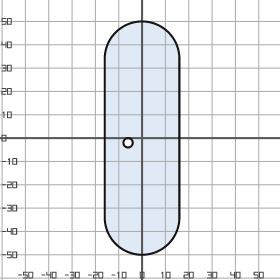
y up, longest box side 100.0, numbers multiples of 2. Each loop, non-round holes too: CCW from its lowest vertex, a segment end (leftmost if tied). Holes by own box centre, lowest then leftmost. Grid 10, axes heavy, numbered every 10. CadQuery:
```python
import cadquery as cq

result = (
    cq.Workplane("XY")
    .moveTo(-16.0, -34.0)
    .threePointArc((0.0, -50.0), (16.0, -34.0))
    .lineTo(16.0, 34.0)
    .threePointArc((0.0, 50.0), (-16.0, 34.0))
    .close()
    .moveTo(-6.0, -2.0)
    .circle(2.0)
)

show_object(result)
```